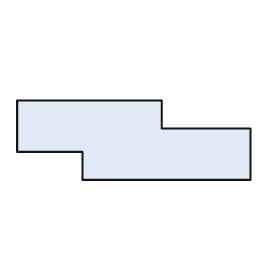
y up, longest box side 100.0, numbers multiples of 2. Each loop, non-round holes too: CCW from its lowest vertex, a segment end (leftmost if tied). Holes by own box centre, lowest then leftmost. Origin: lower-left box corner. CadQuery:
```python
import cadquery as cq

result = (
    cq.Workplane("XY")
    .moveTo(28.0, 0.0)
    .lineTo(100.0, 0.0)
    .lineTo(100.0, 22.0)
    .lineTo(62.0, 22.0)
    .lineTo(62.0, 34.0)
    .lineTo(0.0, 34.0)
    .lineTo(0.0, 12.0)
    .lineTo(28.0, 12.0)
    .close()
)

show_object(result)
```